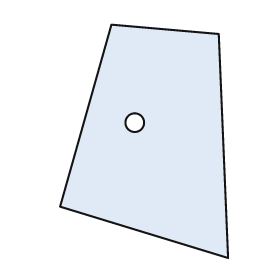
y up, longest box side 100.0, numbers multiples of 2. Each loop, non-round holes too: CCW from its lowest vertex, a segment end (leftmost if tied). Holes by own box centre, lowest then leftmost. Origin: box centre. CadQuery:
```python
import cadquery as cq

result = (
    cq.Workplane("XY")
    .moveTo(36.0, -50.0)
    .lineTo(32.0, 46.0)
    .lineTo(-14.0, 50.0)
    .lineTo(-36.0, -28.0)
    .close()
    .moveTo(-4.0, 8.0)
    .circle(4.0)
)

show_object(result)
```